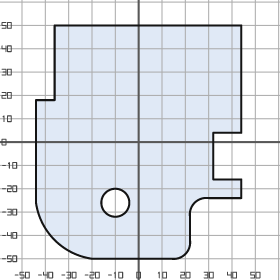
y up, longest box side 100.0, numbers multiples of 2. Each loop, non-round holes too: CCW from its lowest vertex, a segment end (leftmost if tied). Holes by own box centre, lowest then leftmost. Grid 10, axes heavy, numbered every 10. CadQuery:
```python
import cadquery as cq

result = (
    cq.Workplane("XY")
    .moveTo(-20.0, -50.0)
    .lineTo(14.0, -50.0)
    .threePointArc((20.0, -48.0), (22.0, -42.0))
    .lineTo(22.0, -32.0)
    .threePointArc((24.0, -26.0), (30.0, -24.0))
    .lineTo(44.0, -24.0)
    .lineTo(44.0, -16.0)
    .lineTo(32.0, -16.0)
    .lineTo(32.0, 4.0)
    .lineTo(44.0, 4.0)
    .lineTo(44.0, 50.0)
    .lineTo(-36.0, 50.0)
    .lineTo(-36.0, 18.0)
    .lineTo(-44.0, 18.0)
    .lineTo(-44.0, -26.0)
    .threePointArc((-36.0, -42.0), (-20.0, -50.0))
    .close()
    .moveTo(-10.0, -26.0)
    .circle(6.0)
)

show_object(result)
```